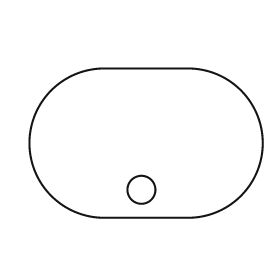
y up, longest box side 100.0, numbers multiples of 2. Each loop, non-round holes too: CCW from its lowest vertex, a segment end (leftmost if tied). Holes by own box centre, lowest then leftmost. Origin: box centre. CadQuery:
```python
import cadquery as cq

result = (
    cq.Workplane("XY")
    .moveTo(-18.0, -32.0)
    .lineTo(18.0, -32.0)
    .threePointArc((50.0, 0.0), (18.0, 32.0))
    .lineTo(-18.0, 32.0)
    .threePointArc((-50.0, 0.0), (-18.0, -32.0))
    .close()
    .moveTo(-2.0, -20.0)
    .circle(6.0)
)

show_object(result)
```